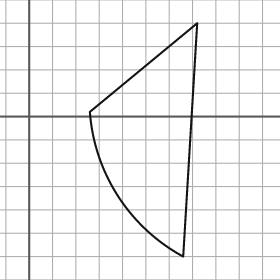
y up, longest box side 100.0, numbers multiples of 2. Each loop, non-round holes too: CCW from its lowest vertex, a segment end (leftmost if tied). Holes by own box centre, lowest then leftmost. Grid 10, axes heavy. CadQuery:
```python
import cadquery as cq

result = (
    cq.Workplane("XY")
    .moveTo(66.0, -60.0)
    .lineTo(72.0, 40.0)
    .lineTo(26.0, 2.0)
    .threePointArc((38.0, -34.0), (66.0, -60.0))
    .close()
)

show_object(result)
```